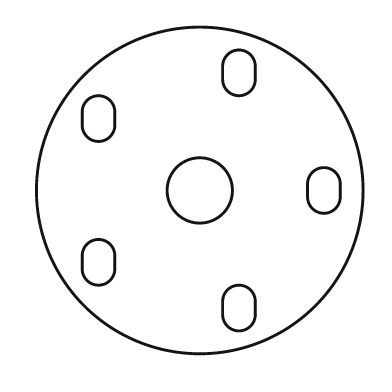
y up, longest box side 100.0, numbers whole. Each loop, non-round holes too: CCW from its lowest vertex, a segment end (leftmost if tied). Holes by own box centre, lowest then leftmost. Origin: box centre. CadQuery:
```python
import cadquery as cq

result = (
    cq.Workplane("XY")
    .moveTo(0.0, 0.0)
    .circle(50.0)
    .moveTo(7.0, -38.0)
    .threePointArc((12.0, -43.0), (17.0, -38.0))
    .lineTo(17.0, -34.0)
    .threePointArc((12.0, -29.0), (7.0, -34.0))
    .close()
    .moveTo(-36.0, -24.0)
    .threePointArc((-31.0, -29.0), (-26.0, -24.0))
    .lineTo(-26.0, -20.0)
    .threePointArc((-31.0, -15.0), (-36.0, -20.0))
    .close()
    .moveTo(0.0, 0.0)
    .circle(10.0)
    .moveTo(33.0, -2.0)
    .threePointArc((38.0, -7.0), (43.0, -2.0))
    .lineTo(43.0, 2.0)
    .threePointArc((38.0, 7.0), (33.0, 2.0))
    .close()
    .moveTo(-36.0, 20.0)
    .threePointArc((-31.0, 15.0), (-26.0, 20.0))
    .lineTo(-26.0, 24.0)
    .threePointArc((-31.0, 29.0), (-36.0, 24.0))
    .close()
    .moveTo(7.0, 34.0)
    .threePointArc((12.0, 29.0), (17.0, 34.0))
    .lineTo(17.0, 38.0)
    .threePointArc((12.0, 43.0), (7.0, 38.0))
    .close()
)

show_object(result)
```